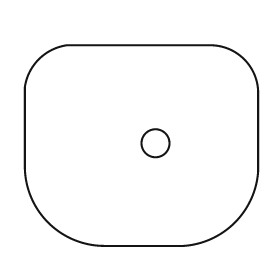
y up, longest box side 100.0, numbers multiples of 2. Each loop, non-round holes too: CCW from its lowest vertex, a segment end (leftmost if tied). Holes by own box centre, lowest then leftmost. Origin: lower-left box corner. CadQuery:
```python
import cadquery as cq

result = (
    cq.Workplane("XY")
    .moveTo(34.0, 0.0)
    .lineTo(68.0, 0.0)
    .threePointArc((90.0, 10.0), (100.0, 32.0))
    .lineTo(100.0, 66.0)
    .threePointArc((94.0, 80.0), (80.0, 86.0))
    .lineTo(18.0, 86.0)
    .threePointArc((6.0, 80.0), (0.0, 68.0))
    .lineTo(0.0, 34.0)
    .threePointArc((10.0, 10.0), (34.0, 0.0))
    .close()
    .moveTo(56.0, 44.0)
    .circle(6.0)
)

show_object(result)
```